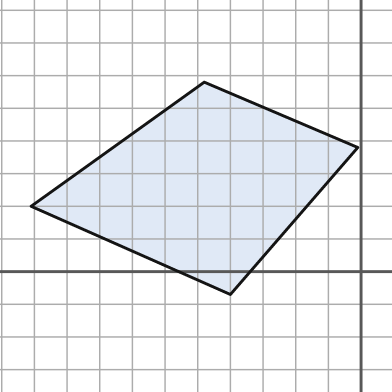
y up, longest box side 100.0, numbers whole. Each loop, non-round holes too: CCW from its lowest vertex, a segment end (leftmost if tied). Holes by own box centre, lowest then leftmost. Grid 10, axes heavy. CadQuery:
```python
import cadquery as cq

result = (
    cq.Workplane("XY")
    .moveTo(-40.0, -7.0)
    .lineTo(-1.0, 38.0)
    .lineTo(-48.0, 58.0)
    .lineTo(-101.0, 20.0)
    .close()
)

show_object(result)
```